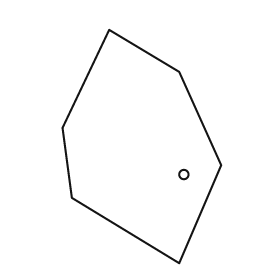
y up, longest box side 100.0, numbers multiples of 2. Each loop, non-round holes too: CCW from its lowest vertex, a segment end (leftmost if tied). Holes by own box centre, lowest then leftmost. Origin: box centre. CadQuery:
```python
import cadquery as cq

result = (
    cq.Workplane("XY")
    .moveTo(16.0, -50.0)
    .lineTo(34.0, -8.0)
    .lineTo(16.0, 32.0)
    .lineTo(-14.0, 50.0)
    .lineTo(-34.0, 8.0)
    .lineTo(-30.0, -22.0)
    .close()
    .moveTo(18.0, -12.0)
    .circle(2.0)
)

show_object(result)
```